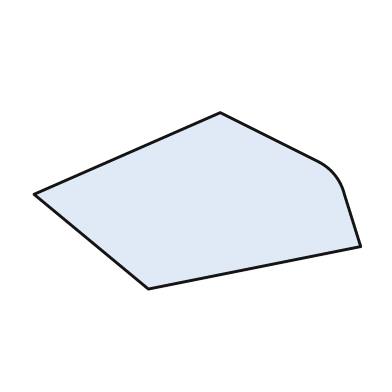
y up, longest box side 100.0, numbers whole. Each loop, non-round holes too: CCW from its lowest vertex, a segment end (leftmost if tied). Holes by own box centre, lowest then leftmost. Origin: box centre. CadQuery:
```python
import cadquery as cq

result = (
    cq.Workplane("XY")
    .moveTo(-15.0, -27.0)
    .lineTo(50.0, -14.0)
    .lineTo(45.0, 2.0)
    .threePointArc((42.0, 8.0), (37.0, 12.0))
    .lineTo(7.0, 27.0)
    .lineTo(-50.0, 2.0)
    .close()
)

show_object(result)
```